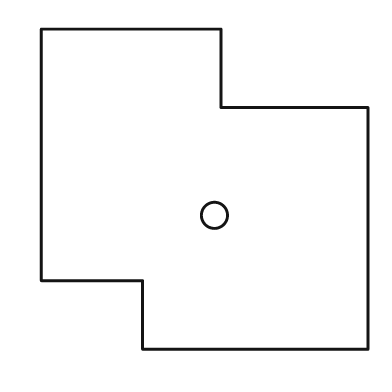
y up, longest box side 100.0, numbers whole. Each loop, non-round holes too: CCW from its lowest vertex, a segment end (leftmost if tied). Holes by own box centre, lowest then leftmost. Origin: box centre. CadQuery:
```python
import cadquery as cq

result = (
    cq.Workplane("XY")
    .moveTo(-19.0, -49.0)
    .lineTo(50.0, -49.0)
    .lineTo(50.0, 25.0)
    .lineTo(5.0, 25.0)
    .lineTo(5.0, 49.0)
    .lineTo(-50.0, 49.0)
    .lineTo(-50.0, -28.0)
    .lineTo(-19.0, -28.0)
    .close()
    .moveTo(3.0, -8.0)
    .circle(4.0)
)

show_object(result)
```